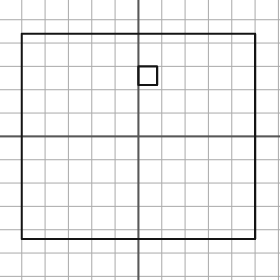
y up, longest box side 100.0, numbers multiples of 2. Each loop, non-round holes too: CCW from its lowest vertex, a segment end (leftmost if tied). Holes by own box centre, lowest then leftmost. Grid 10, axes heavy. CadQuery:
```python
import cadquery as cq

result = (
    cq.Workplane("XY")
    .moveTo(-50.0, -44.0)
    .lineTo(50.0, -44.0)
    .lineTo(50.0, 44.0)
    .lineTo(-50.0, 44.0)
    .close()
    .moveTo(0.0, 22.0)
    .lineTo(8.0, 22.0)
    .lineTo(8.0, 30.0)
    .lineTo(0.0, 30.0)
    .close()
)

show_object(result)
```